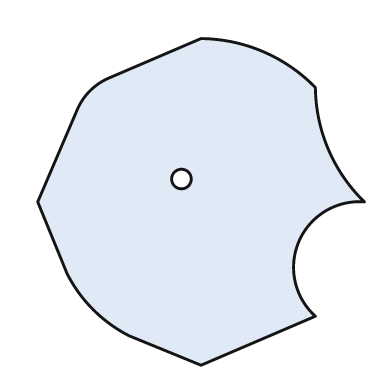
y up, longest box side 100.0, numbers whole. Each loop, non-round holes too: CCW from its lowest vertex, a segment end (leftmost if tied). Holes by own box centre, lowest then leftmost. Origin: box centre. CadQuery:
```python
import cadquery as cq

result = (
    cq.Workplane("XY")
    .moveTo(0.0, -50.0)
    .lineTo(35.0, -35.0)
    .threePointArc((30.0, -12.0), (50.0, 0.0))
    .threePointArc((39.0, 16.0), (35.0, 35.0))
    .threePointArc((19.0, 46.0), (0.0, 50.0))
    .lineTo(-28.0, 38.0)
    .threePointArc((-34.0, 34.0), (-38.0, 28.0))
    .lineTo(-50.0, 0.0)
    .lineTo(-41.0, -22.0)
    .threePointArc((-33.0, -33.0), (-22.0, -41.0))
    .close()
    .moveTo(-6.0, 7.0)
    .circle(3.0)
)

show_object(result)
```